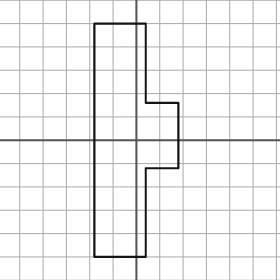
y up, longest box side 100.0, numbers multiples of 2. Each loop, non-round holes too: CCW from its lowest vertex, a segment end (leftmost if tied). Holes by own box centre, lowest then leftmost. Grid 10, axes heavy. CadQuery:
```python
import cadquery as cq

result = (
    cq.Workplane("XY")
    .moveTo(-18.0, -50.0)
    .lineTo(4.0, -50.0)
    .lineTo(4.0, -12.0)
    .lineTo(18.0, -12.0)
    .lineTo(18.0, 16.0)
    .lineTo(4.0, 16.0)
    .lineTo(4.0, 50.0)
    .lineTo(-18.0, 50.0)
    .close()
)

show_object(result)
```